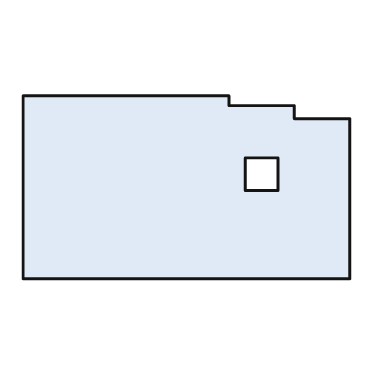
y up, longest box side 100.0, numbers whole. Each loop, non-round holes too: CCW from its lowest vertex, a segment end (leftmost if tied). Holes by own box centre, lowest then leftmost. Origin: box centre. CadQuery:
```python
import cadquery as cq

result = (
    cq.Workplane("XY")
    .moveTo(-50.0, -28.0)
    .lineTo(50.0, -28.0)
    .lineTo(50.0, 21.0)
    .lineTo(33.0, 21.0)
    .lineTo(33.0, 25.0)
    .lineTo(13.0, 25.0)
    .lineTo(13.0, 28.0)
    .lineTo(-50.0, 28.0)
    .close()
    .moveTo(18.0, -1.0)
    .lineTo(28.0, -1.0)
    .lineTo(28.0, 9.0)
    .lineTo(18.0, 9.0)
    .close()
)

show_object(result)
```